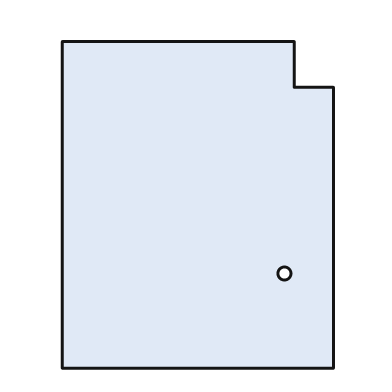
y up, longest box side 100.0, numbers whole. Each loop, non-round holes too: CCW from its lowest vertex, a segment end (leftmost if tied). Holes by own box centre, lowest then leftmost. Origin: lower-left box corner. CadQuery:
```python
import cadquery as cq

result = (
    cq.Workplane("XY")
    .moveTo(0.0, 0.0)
    .lineTo(83.0, 0.0)
    .lineTo(83.0, 86.0)
    .lineTo(71.0, 86.0)
    .lineTo(71.0, 100.0)
    .lineTo(0.0, 100.0)
    .close()
    .moveTo(68.0, 29.0)
    .circle(2.0)
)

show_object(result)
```